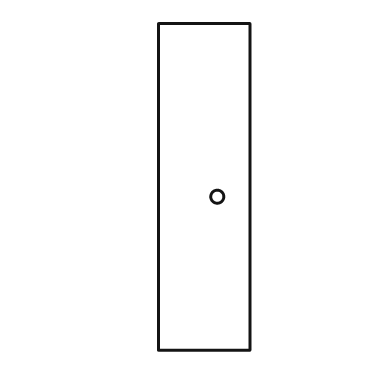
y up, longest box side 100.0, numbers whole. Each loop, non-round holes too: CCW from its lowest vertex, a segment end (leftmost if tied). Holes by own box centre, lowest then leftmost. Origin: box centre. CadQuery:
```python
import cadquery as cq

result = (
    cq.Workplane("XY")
    .moveTo(-14.0, -50.0)
    .lineTo(14.0, -50.0)
    .lineTo(14.0, 50.0)
    .lineTo(-14.0, 50.0)
    .close()
    .moveTo(4.0, -3.0)
    .circle(2.0)
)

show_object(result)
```